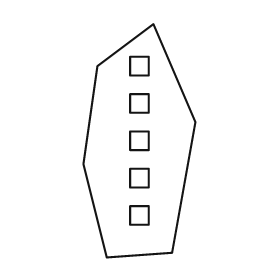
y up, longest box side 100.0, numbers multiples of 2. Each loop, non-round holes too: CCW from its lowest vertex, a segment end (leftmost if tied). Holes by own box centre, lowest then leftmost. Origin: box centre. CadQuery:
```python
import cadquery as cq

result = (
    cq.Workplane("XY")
    .moveTo(-14.0, -50.0)
    .lineTo(14.0, -48.0)
    .lineTo(24.0, 8.0)
    .lineTo(6.0, 50.0)
    .lineTo(-18.0, 32.0)
    .lineTo(-24.0, -10.0)
    .close()
    .moveTo(-4.0, -36.0)
    .lineTo(4.0, -36.0)
    .lineTo(4.0, -28.0)
    .lineTo(-4.0, -28.0)
    .close()
    .moveTo(-4.0, -20.0)
    .lineTo(4.0, -20.0)
    .lineTo(4.0, -12.0)
    .lineTo(-4.0, -12.0)
    .close()
    .moveTo(-4.0, -4.0)
    .lineTo(4.0, -4.0)
    .lineTo(4.0, 4.0)
    .lineTo(-4.0, 4.0)
    .close()
    .moveTo(-4.0, 12.0)
    .lineTo(4.0, 12.0)
    .lineTo(4.0, 20.0)
    .lineTo(-4.0, 20.0)
    .close()
    .moveTo(-4.0, 28.0)
    .lineTo(4.0, 28.0)
    .lineTo(4.0, 36.0)
    .lineTo(-4.0, 36.0)
    .close()
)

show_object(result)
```